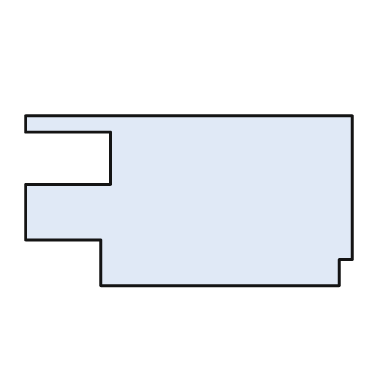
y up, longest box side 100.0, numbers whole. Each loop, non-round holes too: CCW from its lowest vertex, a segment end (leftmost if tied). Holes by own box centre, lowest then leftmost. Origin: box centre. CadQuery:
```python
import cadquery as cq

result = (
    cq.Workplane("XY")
    .moveTo(-27.0, -26.0)
    .lineTo(46.0, -26.0)
    .lineTo(46.0, -18.0)
    .lineTo(50.0, -18.0)
    .lineTo(50.0, 26.0)
    .lineTo(-50.0, 26.0)
    .lineTo(-50.0, 21.0)
    .lineTo(-24.0, 21.0)
    .lineTo(-24.0, 5.0)
    .lineTo(-50.0, 5.0)
    .lineTo(-50.0, -12.0)
    .lineTo(-27.0, -12.0)
    .close()
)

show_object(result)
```